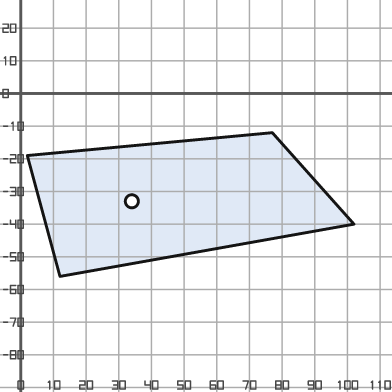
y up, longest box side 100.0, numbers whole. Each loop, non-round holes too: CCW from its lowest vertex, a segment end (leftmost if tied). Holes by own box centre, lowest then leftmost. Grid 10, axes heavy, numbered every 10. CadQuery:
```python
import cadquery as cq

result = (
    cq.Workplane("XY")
    .moveTo(12.0, -56.0)
    .lineTo(102.0, -40.0)
    .lineTo(77.0, -12.0)
    .lineTo(2.0, -19.0)
    .close()
    .moveTo(34.0, -33.0)
    .circle(2.0)
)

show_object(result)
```